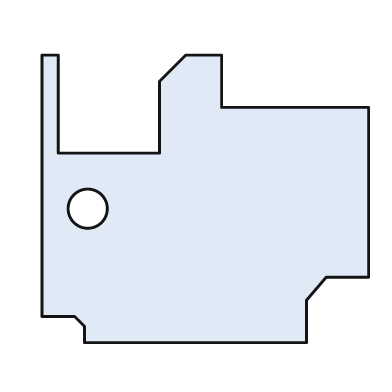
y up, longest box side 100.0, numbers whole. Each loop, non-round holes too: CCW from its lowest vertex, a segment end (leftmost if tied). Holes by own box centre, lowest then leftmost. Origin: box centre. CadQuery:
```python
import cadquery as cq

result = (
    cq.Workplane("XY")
    .moveTo(-37.0, -44.0)
    .lineTo(31.0, -44.0)
    .lineTo(31.0, -31.0)
    .lineTo(37.0, -24.0)
    .lineTo(50.0, -24.0)
    .lineTo(50.0, 28.0)
    .lineTo(5.0, 28.0)
    .lineTo(5.0, 44.0)
    .lineTo(-6.0, 44.0)
    .lineTo(-14.0, 36.0)
    .lineTo(-14.0, 14.0)
    .lineTo(-45.0, 14.0)
    .lineTo(-45.0, 44.0)
    .lineTo(-50.0, 44.0)
    .lineTo(-50.0, -36.0)
    .lineTo(-40.0, -36.0)
    .lineTo(-37.0, -39.0)
    .close()
    .moveTo(-36.0, -3.0)
    .circle(6.0)
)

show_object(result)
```